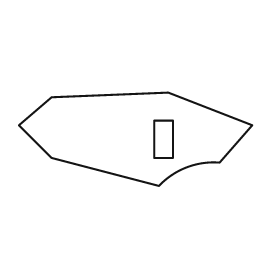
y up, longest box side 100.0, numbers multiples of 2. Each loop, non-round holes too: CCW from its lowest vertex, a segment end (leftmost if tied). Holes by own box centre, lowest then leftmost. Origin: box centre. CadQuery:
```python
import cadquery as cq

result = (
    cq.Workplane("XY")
    .moveTo(10.0, -20.0)
    .threePointArc((22.0, -12.0), (36.0, -10.0))
    .lineTo(50.0, 6.0)
    .lineTo(14.0, 20.0)
    .lineTo(-36.0, 18.0)
    .lineTo(-50.0, 6.0)
    .lineTo(-36.0, -8.0)
    .close()
    .moveTo(8.0, -8.0)
    .lineTo(16.0, -8.0)
    .lineTo(16.0, 8.0)
    .lineTo(8.0, 8.0)
    .close()
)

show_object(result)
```